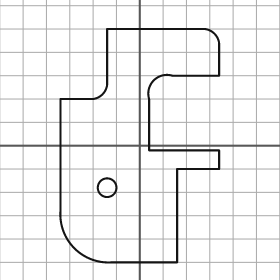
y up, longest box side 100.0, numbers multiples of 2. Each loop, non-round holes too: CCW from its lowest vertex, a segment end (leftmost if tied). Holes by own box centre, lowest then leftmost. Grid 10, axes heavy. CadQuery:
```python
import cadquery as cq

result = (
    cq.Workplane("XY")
    .moveTo(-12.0, -50.0)
    .lineTo(16.0, -50.0)
    .lineTo(16.0, -10.0)
    .lineTo(34.0, -10.0)
    .lineTo(34.0, -2.0)
    .lineTo(4.0, -2.0)
    .lineTo(4.0, 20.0)
    .threePointArc((6.0, 28.0), (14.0, 30.0))
    .lineTo(34.0, 30.0)
    .lineTo(34.0, 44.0)
    .threePointArc((32.0, 48.0), (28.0, 50.0))
    .lineTo(-14.0, 50.0)
    .lineTo(-14.0, 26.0)
    .threePointArc((-16.0, 22.0), (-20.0, 20.0))
    .lineTo(-34.0, 20.0)
    .lineTo(-34.0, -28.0)
    .threePointArc((-28.0, -44.0), (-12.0, -50.0))
    .close()
    .moveTo(-14.0, -18.0)
    .circle(4.0)
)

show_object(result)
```